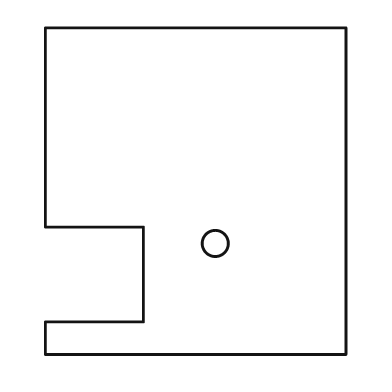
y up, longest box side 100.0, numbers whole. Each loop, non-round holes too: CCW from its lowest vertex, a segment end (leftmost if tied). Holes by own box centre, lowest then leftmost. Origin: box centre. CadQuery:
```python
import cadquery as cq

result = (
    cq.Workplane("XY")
    .moveTo(-46.0, -50.0)
    .lineTo(46.0, -50.0)
    .lineTo(46.0, 50.0)
    .lineTo(-46.0, 50.0)
    .lineTo(-46.0, -11.0)
    .lineTo(-16.0, -11.0)
    .lineTo(-16.0, -40.0)
    .lineTo(-46.0, -40.0)
    .close()
    .moveTo(6.0, -16.0)
    .circle(4.0)
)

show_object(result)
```